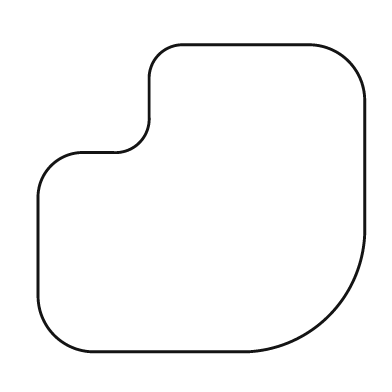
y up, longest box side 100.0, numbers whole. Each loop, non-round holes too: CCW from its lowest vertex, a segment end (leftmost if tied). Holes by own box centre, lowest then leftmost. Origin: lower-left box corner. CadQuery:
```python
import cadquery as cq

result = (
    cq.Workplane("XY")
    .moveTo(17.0, 0.0)
    .lineTo(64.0, 0.0)
    .threePointArc((89.0, 11.0), (100.0, 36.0))
    .lineTo(100.0, 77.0)
    .threePointArc((95.0, 89.0), (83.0, 94.0))
    .lineTo(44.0, 94.0)
    .threePointArc((37.0, 91.0), (34.0, 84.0))
    .lineTo(34.0, 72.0)
    .threePointArc((31.0, 64.0), (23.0, 61.0))
    .lineTo(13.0, 61.0)
    .threePointArc((4.0, 57.0), (0.0, 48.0))
    .lineTo(0.0, 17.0)
    .threePointArc((5.0, 5.0), (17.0, 0.0))
    .close()
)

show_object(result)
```